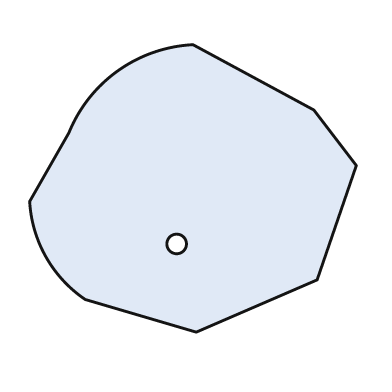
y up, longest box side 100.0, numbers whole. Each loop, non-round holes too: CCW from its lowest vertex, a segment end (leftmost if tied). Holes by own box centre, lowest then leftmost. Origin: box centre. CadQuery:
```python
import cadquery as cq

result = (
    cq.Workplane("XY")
    .moveTo(1.0, -44.0)
    .lineTo(38.0, -28.0)
    .lineTo(50.0, 7.0)
    .lineTo(37.0, 24.0)
    .lineTo(0.0, 44.0)
    .threePointArc((-23.0, 36.0), (-38.0, 17.0))
    .lineTo(-50.0, -4.0)
    .threePointArc((-45.0, -21.0), (-33.0, -34.0))
    .close()
    .moveTo(-5.0, -17.0)
    .circle(3.0)
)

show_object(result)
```